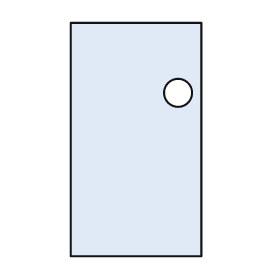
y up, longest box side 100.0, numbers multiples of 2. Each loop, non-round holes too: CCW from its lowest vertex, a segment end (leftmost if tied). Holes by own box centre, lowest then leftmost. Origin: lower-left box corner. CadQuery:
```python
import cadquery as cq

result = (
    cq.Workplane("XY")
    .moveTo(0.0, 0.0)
    .lineTo(56.0, 0.0)
    .lineTo(56.0, 100.0)
    .lineTo(0.0, 100.0)
    .close()
    .moveTo(46.0, 70.0)
    .circle(6.0)
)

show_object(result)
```